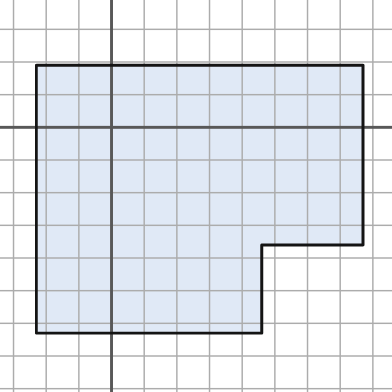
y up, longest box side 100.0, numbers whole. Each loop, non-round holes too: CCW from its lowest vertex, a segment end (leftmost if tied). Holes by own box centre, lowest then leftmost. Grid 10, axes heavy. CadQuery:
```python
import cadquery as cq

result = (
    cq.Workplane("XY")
    .moveTo(-23.0, -63.0)
    .lineTo(46.0, -63.0)
    .lineTo(46.0, -36.0)
    .lineTo(77.0, -36.0)
    .lineTo(77.0, 19.0)
    .lineTo(-23.0, 19.0)
    .close()
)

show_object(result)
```